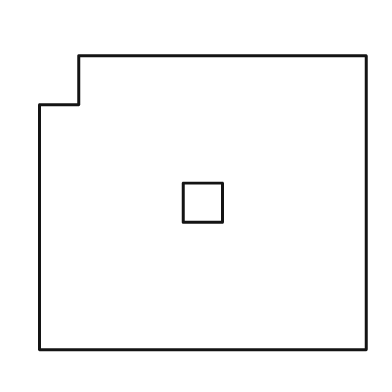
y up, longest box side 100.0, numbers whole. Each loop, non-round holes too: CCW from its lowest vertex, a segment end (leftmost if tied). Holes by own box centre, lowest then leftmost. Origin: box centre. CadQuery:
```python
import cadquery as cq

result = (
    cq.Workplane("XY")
    .moveTo(-50.0, -45.0)
    .lineTo(50.0, -45.0)
    .lineTo(50.0, 45.0)
    .lineTo(-38.0, 45.0)
    .lineTo(-38.0, 30.0)
    .lineTo(-50.0, 30.0)
    .close()
    .moveTo(-6.0, -6.0)
    .lineTo(6.0, -6.0)
    .lineTo(6.0, 6.0)
    .lineTo(-6.0, 6.0)
    .close()
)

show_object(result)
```